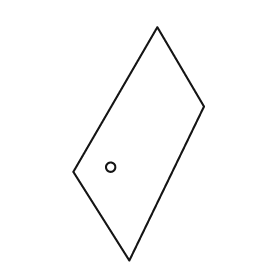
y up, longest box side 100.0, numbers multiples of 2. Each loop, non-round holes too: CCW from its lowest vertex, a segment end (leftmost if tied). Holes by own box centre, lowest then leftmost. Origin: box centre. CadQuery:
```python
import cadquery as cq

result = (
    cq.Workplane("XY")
    .moveTo(-4.0, -50.0)
    .lineTo(28.0, 16.0)
    .lineTo(8.0, 50.0)
    .lineTo(-28.0, -12.0)
    .close()
    .moveTo(-12.0, -10.0)
    .circle(2.0)
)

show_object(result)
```